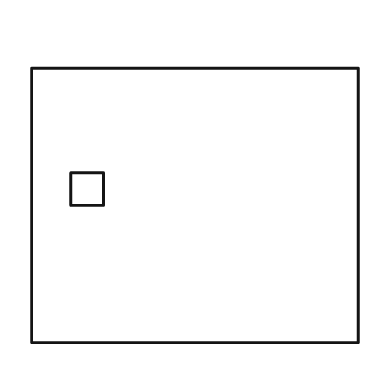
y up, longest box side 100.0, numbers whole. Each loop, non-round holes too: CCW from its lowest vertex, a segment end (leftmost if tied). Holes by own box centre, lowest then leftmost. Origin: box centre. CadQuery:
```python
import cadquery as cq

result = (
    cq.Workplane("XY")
    .moveTo(-50.0, -42.0)
    .lineTo(50.0, -42.0)
    .lineTo(50.0, 42.0)
    .lineTo(-50.0, 42.0)
    .close()
    .moveTo(-38.0, 0.0)
    .lineTo(-28.0, 0.0)
    .lineTo(-28.0, 10.0)
    .lineTo(-38.0, 10.0)
    .close()
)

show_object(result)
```